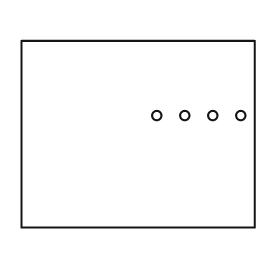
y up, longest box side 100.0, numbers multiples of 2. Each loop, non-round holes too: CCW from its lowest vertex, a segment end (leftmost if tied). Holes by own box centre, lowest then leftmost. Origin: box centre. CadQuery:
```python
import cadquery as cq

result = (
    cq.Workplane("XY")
    .moveTo(-50.0, -40.0)
    .lineTo(50.0, -40.0)
    .lineTo(50.0, 40.0)
    .lineTo(-50.0, 40.0)
    .close()
    .moveTo(8.0, 8.0)
    .circle(2.0)
    .moveTo(20.0, 8.0)
    .circle(2.0)
    .moveTo(32.0, 8.0)
    .circle(2.0)
    .moveTo(44.0, 8.0)
    .circle(2.0)
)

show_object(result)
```